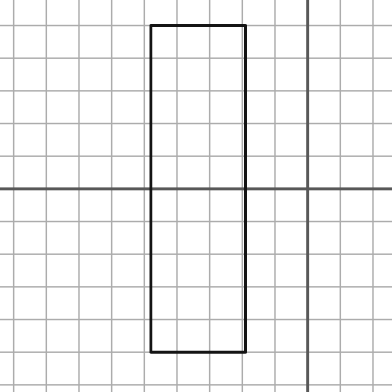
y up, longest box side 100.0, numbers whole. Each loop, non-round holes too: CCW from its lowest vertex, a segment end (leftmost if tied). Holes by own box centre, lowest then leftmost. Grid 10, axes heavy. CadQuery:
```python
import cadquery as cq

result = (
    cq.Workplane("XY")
    .moveTo(-48.0, -50.0)
    .lineTo(-19.0, -50.0)
    .lineTo(-19.0, 50.0)
    .lineTo(-48.0, 50.0)
    .close()
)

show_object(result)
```